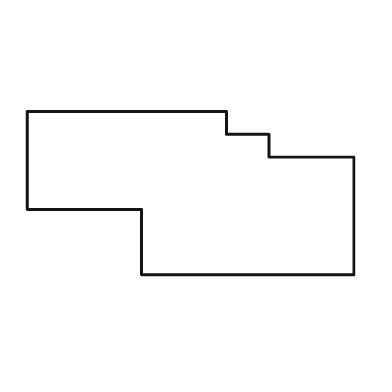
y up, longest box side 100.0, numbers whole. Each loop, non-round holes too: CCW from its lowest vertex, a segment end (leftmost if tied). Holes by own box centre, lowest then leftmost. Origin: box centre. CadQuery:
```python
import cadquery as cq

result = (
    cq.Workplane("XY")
    .moveTo(-15.0, -25.0)
    .lineTo(50.0, -25.0)
    .lineTo(50.0, 11.0)
    .lineTo(24.0, 11.0)
    .lineTo(24.0, 18.0)
    .lineTo(11.0, 18.0)
    .lineTo(11.0, 25.0)
    .lineTo(-50.0, 25.0)
    .lineTo(-50.0, -5.0)
    .lineTo(-15.0, -5.0)
    .close()
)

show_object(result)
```